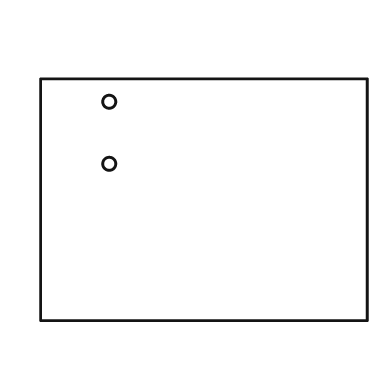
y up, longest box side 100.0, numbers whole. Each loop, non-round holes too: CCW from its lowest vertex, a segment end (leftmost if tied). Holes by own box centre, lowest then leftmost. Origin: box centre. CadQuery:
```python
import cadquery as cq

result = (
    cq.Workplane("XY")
    .moveTo(-50.0, -37.0)
    .lineTo(50.0, -37.0)
    .lineTo(50.0, 37.0)
    .lineTo(-50.0, 37.0)
    .close()
    .moveTo(-29.0, 11.0)
    .circle(2.0)
    .moveTo(-29.0, 30.0)
    .circle(2.0)
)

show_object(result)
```